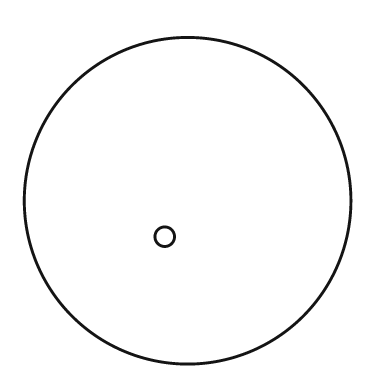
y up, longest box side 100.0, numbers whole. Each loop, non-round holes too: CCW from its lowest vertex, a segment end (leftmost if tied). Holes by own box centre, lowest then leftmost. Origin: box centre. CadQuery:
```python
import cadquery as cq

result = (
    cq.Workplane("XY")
    .moveTo(0.0, 0.0)
    .circle(50.0)
    .moveTo(-7.0, -11.0)
    .circle(3.0)
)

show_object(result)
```